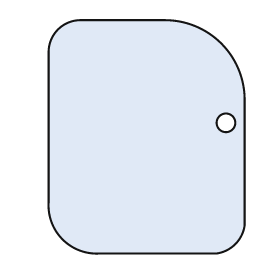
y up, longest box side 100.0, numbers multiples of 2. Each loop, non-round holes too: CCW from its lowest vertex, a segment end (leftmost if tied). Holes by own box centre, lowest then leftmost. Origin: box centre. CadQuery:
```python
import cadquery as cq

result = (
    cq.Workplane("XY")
    .moveTo(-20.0, -50.0)
    .lineTo(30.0, -50.0)
    .threePointArc((38.0, -46.0), (42.0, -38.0))
    .lineTo(42.0, 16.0)
    .threePointArc((32.0, 40.0), (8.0, 50.0))
    .lineTo(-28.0, 50.0)
    .threePointArc((-38.0, 46.0), (-42.0, 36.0))
    .lineTo(-42.0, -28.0)
    .threePointArc((-36.0, -44.0), (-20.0, -50.0))
    .close()
    .moveTo(34.0, 6.0)
    .circle(4.0)
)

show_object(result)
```